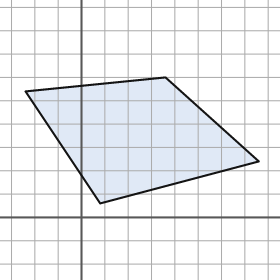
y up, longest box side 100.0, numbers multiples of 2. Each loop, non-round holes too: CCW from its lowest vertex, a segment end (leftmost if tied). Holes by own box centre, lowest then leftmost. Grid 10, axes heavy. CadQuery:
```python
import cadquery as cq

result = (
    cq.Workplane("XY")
    .moveTo(8.0, 6.0)
    .lineTo(76.0, 24.0)
    .lineTo(36.0, 60.0)
    .lineTo(-24.0, 54.0)
    .close()
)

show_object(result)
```